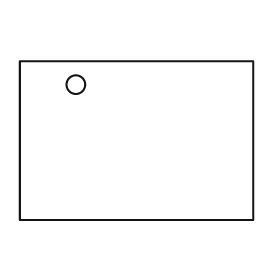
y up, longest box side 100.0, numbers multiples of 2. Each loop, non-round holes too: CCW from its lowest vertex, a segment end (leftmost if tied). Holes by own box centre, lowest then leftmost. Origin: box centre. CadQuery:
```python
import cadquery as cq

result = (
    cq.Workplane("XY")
    .moveTo(-50.0, -34.0)
    .lineTo(50.0, -34.0)
    .lineTo(50.0, 34.0)
    .lineTo(-50.0, 34.0)
    .close()
    .moveTo(-26.0, 24.0)
    .circle(4.0)
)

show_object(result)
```